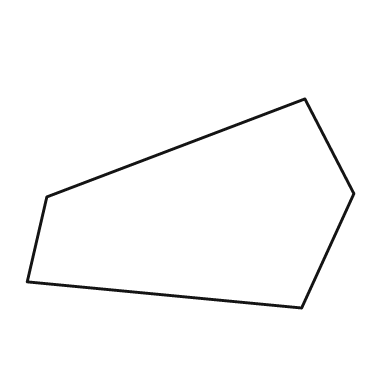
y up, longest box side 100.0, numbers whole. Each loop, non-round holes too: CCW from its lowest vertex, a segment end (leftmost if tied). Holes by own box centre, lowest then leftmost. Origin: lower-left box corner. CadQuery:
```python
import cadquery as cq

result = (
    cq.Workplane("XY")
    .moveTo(84.0, 0.0)
    .lineTo(100.0, 35.0)
    .lineTo(85.0, 64.0)
    .lineTo(6.0, 34.0)
    .lineTo(0.0, 8.0)
    .close()
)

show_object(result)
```